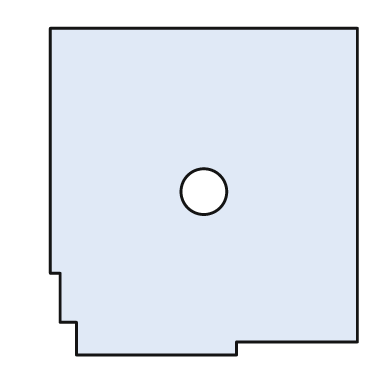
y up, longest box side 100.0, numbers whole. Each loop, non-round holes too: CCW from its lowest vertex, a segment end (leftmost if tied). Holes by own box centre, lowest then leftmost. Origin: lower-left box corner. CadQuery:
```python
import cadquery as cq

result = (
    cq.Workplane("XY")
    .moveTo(8.0, 0.0)
    .lineTo(57.0, 0.0)
    .lineTo(57.0, 4.0)
    .lineTo(94.0, 4.0)
    .lineTo(94.0, 100.0)
    .lineTo(0.0, 100.0)
    .lineTo(0.0, 25.0)
    .lineTo(3.0, 25.0)
    .lineTo(3.0, 10.0)
    .lineTo(8.0, 10.0)
    .close()
    .moveTo(47.0, 50.0)
    .circle(7.0)
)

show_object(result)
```